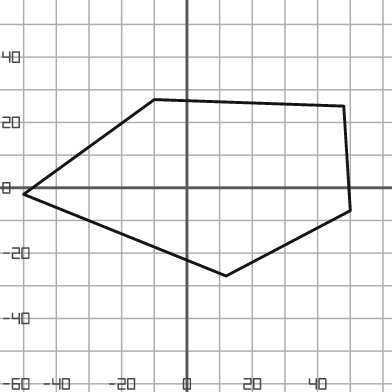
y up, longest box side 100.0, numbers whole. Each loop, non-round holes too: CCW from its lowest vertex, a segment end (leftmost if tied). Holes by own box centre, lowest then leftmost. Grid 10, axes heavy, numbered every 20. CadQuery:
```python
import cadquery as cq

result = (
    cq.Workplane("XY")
    .moveTo(12.0, -27.0)
    .lineTo(50.0, -7.0)
    .lineTo(48.0, 25.0)
    .lineTo(-10.0, 27.0)
    .lineTo(-50.0, -2.0)
    .close()
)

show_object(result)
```